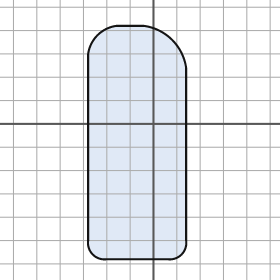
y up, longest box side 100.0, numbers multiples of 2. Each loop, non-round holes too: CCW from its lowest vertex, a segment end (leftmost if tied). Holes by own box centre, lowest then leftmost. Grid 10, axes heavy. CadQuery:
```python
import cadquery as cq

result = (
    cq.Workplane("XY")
    .moveTo(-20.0, -58.0)
    .lineTo(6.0, -58.0)
    .threePointArc((12.0, -56.0), (14.0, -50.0))
    .lineTo(14.0, 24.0)
    .threePointArc((8.0, 36.0), (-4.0, 42.0))
    .lineTo(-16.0, 42.0)
    .threePointArc((-24.0, 38.0), (-28.0, 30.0))
    .lineTo(-28.0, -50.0)
    .threePointArc((-26.0, -56.0), (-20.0, -58.0))
    .close()
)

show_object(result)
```